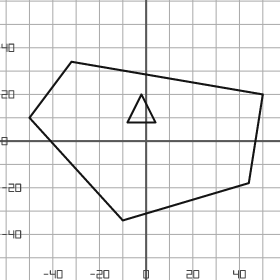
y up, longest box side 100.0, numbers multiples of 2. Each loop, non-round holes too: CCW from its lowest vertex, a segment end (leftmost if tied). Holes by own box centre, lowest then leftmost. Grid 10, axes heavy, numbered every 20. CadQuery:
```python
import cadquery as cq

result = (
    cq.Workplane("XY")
    .moveTo(-10.0, -34.0)
    .lineTo(44.0, -18.0)
    .lineTo(50.0, 20.0)
    .lineTo(-32.0, 34.0)
    .lineTo(-50.0, 10.0)
    .close()
    .moveTo(-8.0, 8.0)
    .lineTo(4.0, 8.0)
    .lineTo(-2.0, 20.0)
    .close()
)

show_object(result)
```